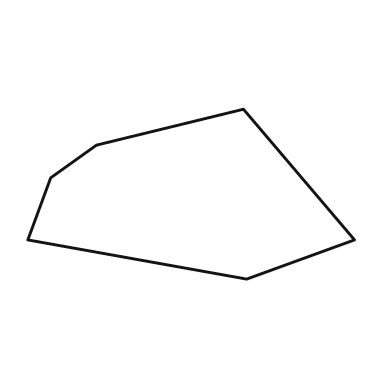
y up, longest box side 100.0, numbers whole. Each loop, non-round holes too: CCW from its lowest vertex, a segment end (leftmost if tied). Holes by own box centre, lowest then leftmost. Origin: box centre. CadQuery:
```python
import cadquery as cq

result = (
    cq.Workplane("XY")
    .moveTo(17.0, -26.0)
    .lineTo(50.0, -14.0)
    .lineTo(16.0, 26.0)
    .lineTo(-29.0, 15.0)
    .lineTo(-43.0, 5.0)
    .lineTo(-50.0, -14.0)
    .close()
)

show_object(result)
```